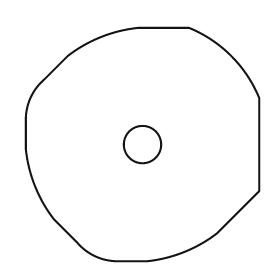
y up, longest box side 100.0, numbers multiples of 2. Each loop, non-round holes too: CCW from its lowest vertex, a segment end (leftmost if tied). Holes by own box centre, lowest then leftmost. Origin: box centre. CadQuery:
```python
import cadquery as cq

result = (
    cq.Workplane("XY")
    .moveTo(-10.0, -50.0)
    .lineTo(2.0, -50.0)
    .threePointArc((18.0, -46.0), (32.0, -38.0))
    .lineTo(50.0, -20.0)
    .lineTo(50.0, 20.0)
    .threePointArc((38.0, 38.0), (20.0, 50.0))
    .lineTo(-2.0, 50.0)
    .threePointArc((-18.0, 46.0), (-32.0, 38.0))
    .lineTo(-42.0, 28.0)
    .threePointArc((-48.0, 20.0), (-50.0, 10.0))
    .lineTo(-50.0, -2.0)
    .threePointArc((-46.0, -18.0), (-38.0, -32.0))
    .lineTo(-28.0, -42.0)
    .threePointArc((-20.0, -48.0), (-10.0, -50.0))
    .close()
    .moveTo(0.0, 0.0)
    .circle(8.0)
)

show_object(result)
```